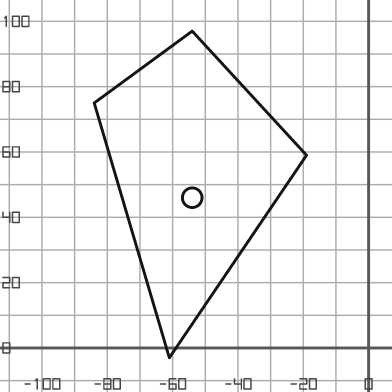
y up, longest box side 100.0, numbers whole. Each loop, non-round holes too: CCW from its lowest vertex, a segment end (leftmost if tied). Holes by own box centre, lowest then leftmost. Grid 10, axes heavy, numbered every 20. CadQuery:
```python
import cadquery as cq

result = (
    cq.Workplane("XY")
    .moveTo(-61.0, -3.0)
    .lineTo(-19.0, 59.0)
    .lineTo(-54.0, 97.0)
    .lineTo(-84.0, 75.0)
    .close()
    .moveTo(-54.0, 46.0)
    .circle(3.0)
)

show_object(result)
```